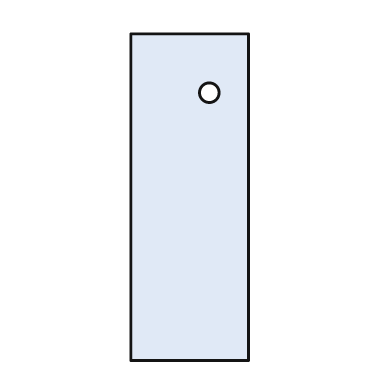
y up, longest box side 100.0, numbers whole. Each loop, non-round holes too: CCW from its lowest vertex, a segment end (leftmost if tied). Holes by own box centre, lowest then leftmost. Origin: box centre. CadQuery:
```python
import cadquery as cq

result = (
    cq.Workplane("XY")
    .moveTo(-18.0, -50.0)
    .lineTo(18.0, -50.0)
    .lineTo(18.0, 50.0)
    .lineTo(-18.0, 50.0)
    .close()
    .moveTo(6.0, 32.0)
    .circle(3.0)
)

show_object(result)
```